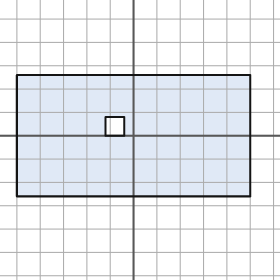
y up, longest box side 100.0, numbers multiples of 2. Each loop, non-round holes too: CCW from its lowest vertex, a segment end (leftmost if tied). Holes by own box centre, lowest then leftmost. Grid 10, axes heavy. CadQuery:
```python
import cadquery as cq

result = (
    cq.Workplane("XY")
    .moveTo(-50.0, -26.0)
    .lineTo(50.0, -26.0)
    .lineTo(50.0, 26.0)
    .lineTo(-50.0, 26.0)
    .close()
    .moveTo(-12.0, 0.0)
    .lineTo(-4.0, 0.0)
    .lineTo(-4.0, 8.0)
    .lineTo(-12.0, 8.0)
    .close()
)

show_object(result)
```